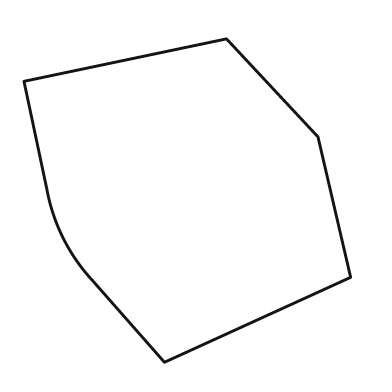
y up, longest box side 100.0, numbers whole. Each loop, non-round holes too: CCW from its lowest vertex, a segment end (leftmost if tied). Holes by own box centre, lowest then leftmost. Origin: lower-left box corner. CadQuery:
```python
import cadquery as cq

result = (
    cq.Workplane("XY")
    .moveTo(43.0, 0.0)
    .lineTo(100.0, 26.0)
    .lineTo(90.0, 69.0)
    .lineTo(62.0, 99.0)
    .lineTo(0.0, 86.0)
    .lineTo(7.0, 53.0)
    .threePointArc((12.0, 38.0), (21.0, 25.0))
    .close()
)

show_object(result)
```